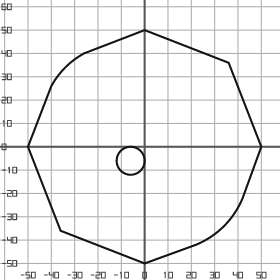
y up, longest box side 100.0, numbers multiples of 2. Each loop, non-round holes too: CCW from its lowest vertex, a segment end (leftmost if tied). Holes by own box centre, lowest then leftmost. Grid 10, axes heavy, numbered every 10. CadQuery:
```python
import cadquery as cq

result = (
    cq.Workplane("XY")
    .moveTo(0.0, -50.0)
    .lineTo(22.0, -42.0)
    .threePointArc((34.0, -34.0), (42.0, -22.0))
    .lineTo(50.0, 0.0)
    .lineTo(36.0, 36.0)
    .lineTo(0.0, 50.0)
    .lineTo(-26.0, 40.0)
    .threePointArc((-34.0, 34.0), (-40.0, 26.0))
    .lineTo(-50.0, 0.0)
    .lineTo(-36.0, -36.0)
    .close()
    .moveTo(-6.0, -6.0)
    .circle(6.0)
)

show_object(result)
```